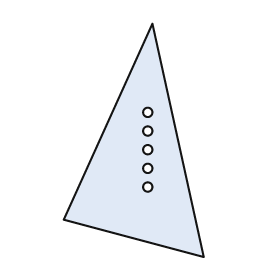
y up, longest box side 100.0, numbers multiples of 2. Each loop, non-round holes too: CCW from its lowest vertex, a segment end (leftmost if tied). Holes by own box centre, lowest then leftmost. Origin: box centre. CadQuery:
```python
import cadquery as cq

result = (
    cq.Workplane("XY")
    .moveTo(30.0, -50.0)
    .lineTo(8.0, 50.0)
    .lineTo(-30.0, -34.0)
    .close()
    .moveTo(6.0, -20.0)
    .circle(2.0)
    .moveTo(6.0, -12.0)
    .circle(2.0)
    .moveTo(6.0, -4.0)
    .circle(2.0)
    .moveTo(6.0, 4.0)
    .circle(2.0)
    .moveTo(6.0, 12.0)
    .circle(2.0)
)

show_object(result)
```